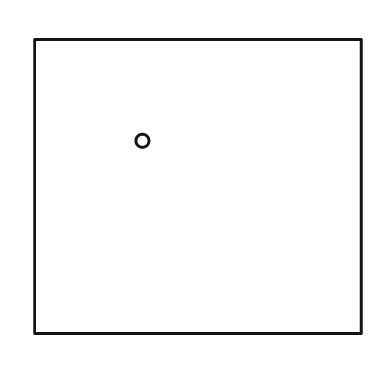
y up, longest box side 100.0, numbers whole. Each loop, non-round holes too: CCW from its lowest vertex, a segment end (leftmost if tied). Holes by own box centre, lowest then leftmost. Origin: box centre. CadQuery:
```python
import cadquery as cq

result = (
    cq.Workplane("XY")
    .moveTo(-50.0, -45.0)
    .lineTo(50.0, -45.0)
    .lineTo(50.0, 45.0)
    .lineTo(-50.0, 45.0)
    .close()
    .moveTo(-17.0, 14.0)
    .circle(2.0)
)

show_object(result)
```